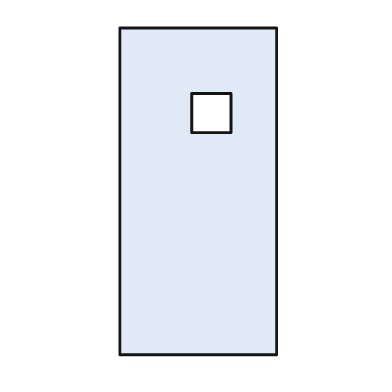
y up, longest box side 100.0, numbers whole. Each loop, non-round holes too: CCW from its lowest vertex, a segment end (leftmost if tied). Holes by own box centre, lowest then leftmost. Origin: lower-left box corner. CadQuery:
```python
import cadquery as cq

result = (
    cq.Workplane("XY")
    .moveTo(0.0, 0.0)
    .lineTo(48.0, 0.0)
    .lineTo(48.0, 100.0)
    .lineTo(0.0, 100.0)
    .close()
    .moveTo(22.0, 68.0)
    .lineTo(34.0, 68.0)
    .lineTo(34.0, 80.0)
    .lineTo(22.0, 80.0)
    .close()
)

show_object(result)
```